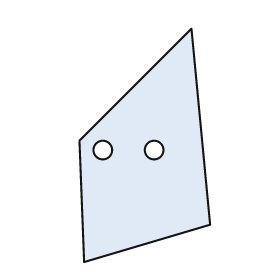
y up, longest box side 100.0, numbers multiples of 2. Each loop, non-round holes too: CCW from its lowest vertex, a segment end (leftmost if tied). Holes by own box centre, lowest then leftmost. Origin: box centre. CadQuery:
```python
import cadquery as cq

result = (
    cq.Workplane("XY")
    .moveTo(-26.0, -50.0)
    .lineTo(28.0, -34.0)
    .lineTo(20.0, 50.0)
    .lineTo(-28.0, 2.0)
    .close()
    .moveTo(-18.0, -2.0)
    .circle(4.0)
    .moveTo(4.0, -2.0)
    .circle(4.0)
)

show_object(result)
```